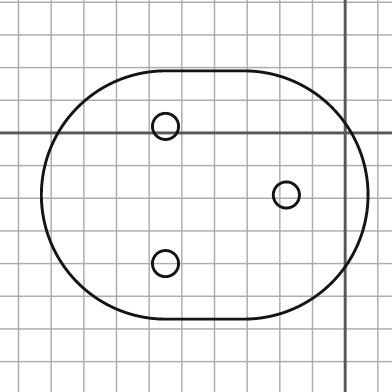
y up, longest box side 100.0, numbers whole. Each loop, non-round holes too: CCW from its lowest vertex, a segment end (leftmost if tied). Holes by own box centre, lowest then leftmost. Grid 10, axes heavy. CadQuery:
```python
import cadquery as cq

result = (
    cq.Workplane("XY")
    .moveTo(-55.0, -57.0)
    .lineTo(-31.0, -57.0)
    .threePointArc((7.0, -19.0), (-31.0, 19.0))
    .lineTo(-55.0, 19.0)
    .threePointArc((-93.0, -19.0), (-55.0, -57.0))
    .close()
    .moveTo(-55.0, -40.0)
    .circle(4.0)
    .moveTo(-18.0, -19.0)
    .circle(4.0)
    .moveTo(-55.0, 2.0)
    .circle(4.0)
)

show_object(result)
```